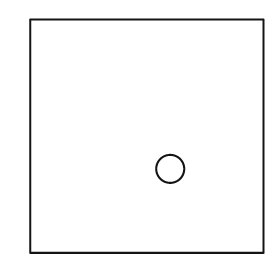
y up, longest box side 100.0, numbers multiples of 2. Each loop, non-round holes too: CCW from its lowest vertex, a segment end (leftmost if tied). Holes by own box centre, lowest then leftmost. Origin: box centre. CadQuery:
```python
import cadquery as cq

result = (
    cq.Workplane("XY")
    .moveTo(-50.0, -50.0)
    .lineTo(50.0, -50.0)
    .lineTo(50.0, 50.0)
    .lineTo(-50.0, 50.0)
    .close()
    .moveTo(10.0, -14.0)
    .circle(6.0)
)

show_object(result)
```